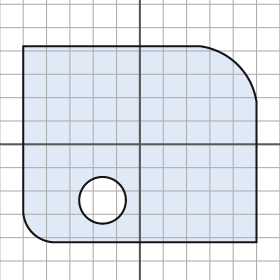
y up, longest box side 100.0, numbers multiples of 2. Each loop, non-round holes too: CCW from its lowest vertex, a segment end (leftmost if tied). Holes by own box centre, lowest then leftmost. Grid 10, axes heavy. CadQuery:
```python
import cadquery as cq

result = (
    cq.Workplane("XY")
    .moveTo(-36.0, -42.0)
    .lineTo(50.0, -42.0)
    .lineTo(50.0, 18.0)
    .threePointArc((42.0, 34.0), (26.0, 42.0))
    .lineTo(-50.0, 42.0)
    .lineTo(-50.0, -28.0)
    .threePointArc((-46.0, -38.0), (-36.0, -42.0))
    .close()
    .moveTo(-16.0, -24.0)
    .circle(10.0)
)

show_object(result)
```